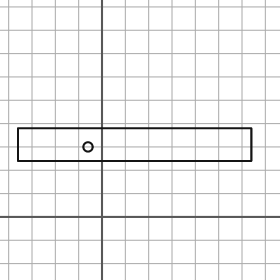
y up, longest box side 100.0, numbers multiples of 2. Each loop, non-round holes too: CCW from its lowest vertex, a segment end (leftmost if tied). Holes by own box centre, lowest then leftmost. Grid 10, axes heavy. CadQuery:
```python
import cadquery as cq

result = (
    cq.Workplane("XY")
    .moveTo(-36.0, 24.0)
    .lineTo(64.0, 24.0)
    .lineTo(64.0, 38.0)
    .lineTo(-36.0, 38.0)
    .close()
    .moveTo(-6.0, 30.0)
    .circle(2.0)
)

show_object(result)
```